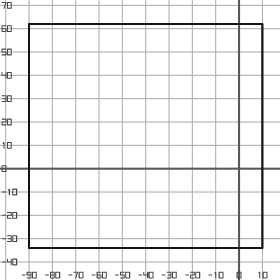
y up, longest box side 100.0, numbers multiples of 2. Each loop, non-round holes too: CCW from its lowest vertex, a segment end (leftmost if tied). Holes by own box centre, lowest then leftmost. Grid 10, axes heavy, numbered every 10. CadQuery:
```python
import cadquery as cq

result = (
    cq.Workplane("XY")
    .moveTo(-90.0, -34.0)
    .lineTo(10.0, -34.0)
    .lineTo(10.0, 62.0)
    .lineTo(-90.0, 62.0)
    .close()
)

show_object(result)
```